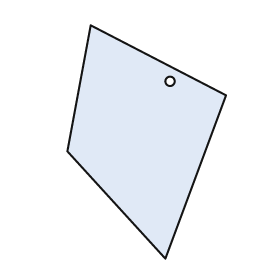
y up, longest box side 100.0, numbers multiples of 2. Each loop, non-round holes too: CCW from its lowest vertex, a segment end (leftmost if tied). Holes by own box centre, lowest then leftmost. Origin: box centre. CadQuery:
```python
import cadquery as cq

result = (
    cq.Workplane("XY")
    .moveTo(8.0, -50.0)
    .lineTo(34.0, 20.0)
    .lineTo(-24.0, 50.0)
    .lineTo(-34.0, -4.0)
    .close()
    .moveTo(10.0, 26.0)
    .circle(2.0)
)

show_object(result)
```